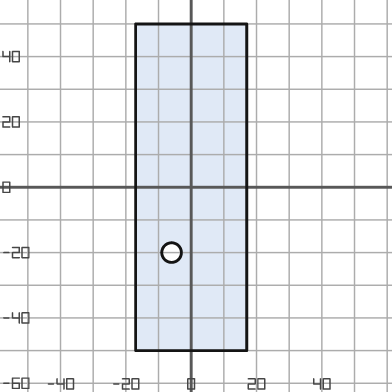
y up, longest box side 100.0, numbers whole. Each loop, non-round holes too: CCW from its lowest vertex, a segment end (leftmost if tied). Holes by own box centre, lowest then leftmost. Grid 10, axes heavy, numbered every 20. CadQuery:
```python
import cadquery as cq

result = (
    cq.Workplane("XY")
    .moveTo(-17.0, -50.0)
    .lineTo(17.0, -50.0)
    .lineTo(17.0, 50.0)
    .lineTo(-17.0, 50.0)
    .close()
    .moveTo(-6.0, -20.0)
    .circle(3.0)
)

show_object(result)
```